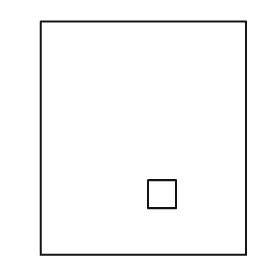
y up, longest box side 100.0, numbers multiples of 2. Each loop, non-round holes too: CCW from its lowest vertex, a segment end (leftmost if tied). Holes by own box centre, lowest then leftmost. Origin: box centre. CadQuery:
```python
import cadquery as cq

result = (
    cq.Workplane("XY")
    .moveTo(-44.0, -50.0)
    .lineTo(44.0, -50.0)
    .lineTo(44.0, 50.0)
    .lineTo(-44.0, 50.0)
    .close()
    .moveTo(2.0, -30.0)
    .lineTo(14.0, -30.0)
    .lineTo(14.0, -18.0)
    .lineTo(2.0, -18.0)
    .close()
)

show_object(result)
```